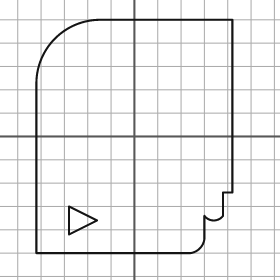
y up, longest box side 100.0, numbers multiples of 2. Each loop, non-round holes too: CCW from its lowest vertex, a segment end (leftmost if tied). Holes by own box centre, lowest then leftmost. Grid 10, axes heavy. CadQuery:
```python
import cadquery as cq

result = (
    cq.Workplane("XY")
    .moveTo(-42.0, -50.0)
    .lineTo(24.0, -50.0)
    .threePointArc((28.0, -48.0), (30.0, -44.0))
    .lineTo(30.0, -34.0)
    .threePointArc((34.0, -36.0), (38.0, -34.0))
    .lineTo(38.0, -24.0)
    .lineTo(42.0, -24.0)
    .lineTo(42.0, 50.0)
    .lineTo(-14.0, 50.0)
    .threePointArc((-34.0, 42.0), (-42.0, 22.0))
    .close()
    .moveTo(-28.0, -42.0)
    .lineTo(-16.0, -36.0)
    .lineTo(-28.0, -30.0)
    .close()
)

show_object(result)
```